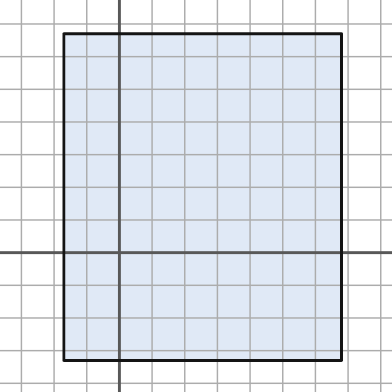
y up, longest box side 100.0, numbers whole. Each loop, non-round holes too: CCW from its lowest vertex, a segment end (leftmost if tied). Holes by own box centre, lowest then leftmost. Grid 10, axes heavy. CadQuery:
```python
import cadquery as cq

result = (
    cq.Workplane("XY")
    .moveTo(-17.0, -33.0)
    .lineTo(68.0, -33.0)
    .lineTo(68.0, 67.0)
    .lineTo(-17.0, 67.0)
    .close()
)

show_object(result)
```